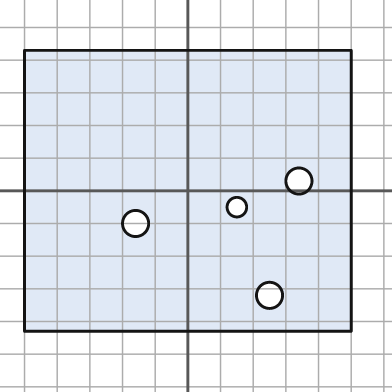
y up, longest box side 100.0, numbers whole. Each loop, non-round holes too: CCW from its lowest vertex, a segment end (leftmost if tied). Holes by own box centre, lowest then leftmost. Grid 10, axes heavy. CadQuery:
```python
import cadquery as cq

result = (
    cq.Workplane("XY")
    .moveTo(-50.0, -43.0)
    .lineTo(50.0, -43.0)
    .lineTo(50.0, 43.0)
    .lineTo(-50.0, 43.0)
    .close()
    .moveTo(25.0, -32.0)
    .circle(4.0)
    .moveTo(-16.0, -10.0)
    .circle(4.0)
    .moveTo(15.0, -5.0)
    .circle(3.0)
    .moveTo(34.0, 3.0)
    .circle(4.0)
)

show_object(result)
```